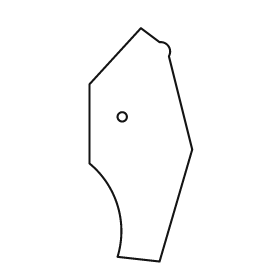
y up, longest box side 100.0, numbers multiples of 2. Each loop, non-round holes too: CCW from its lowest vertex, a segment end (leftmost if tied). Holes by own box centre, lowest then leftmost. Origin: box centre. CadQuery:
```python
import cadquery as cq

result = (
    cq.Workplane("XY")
    .moveTo(8.0, -50.0)
    .lineTo(22.0, -2.0)
    .lineTo(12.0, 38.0)
    .threePointArc((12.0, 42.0), (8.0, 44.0))
    .lineTo(0.0, 50.0)
    .lineTo(-22.0, 26.0)
    .lineTo(-22.0, -8.0)
    .threePointArc((-10.0, -26.0), (-10.0, -48.0))
    .close()
    .moveTo(-8.0, 12.0)
    .circle(2.0)
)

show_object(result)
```